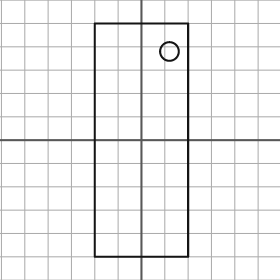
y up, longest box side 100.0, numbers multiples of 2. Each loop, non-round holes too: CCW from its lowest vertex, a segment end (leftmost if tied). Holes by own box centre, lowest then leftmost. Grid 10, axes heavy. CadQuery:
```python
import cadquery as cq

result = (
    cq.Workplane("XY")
    .moveTo(-20.0, -50.0)
    .lineTo(20.0, -50.0)
    .lineTo(20.0, 50.0)
    .lineTo(-20.0, 50.0)
    .close()
    .moveTo(12.0, 38.0)
    .circle(4.0)
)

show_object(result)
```